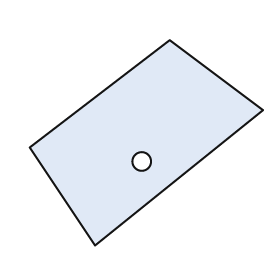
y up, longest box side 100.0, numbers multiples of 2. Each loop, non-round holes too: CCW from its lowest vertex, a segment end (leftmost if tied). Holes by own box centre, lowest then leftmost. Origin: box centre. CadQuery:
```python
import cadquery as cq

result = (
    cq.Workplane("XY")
    .moveTo(-22.0, -44.0)
    .lineTo(50.0, 14.0)
    .lineTo(10.0, 44.0)
    .lineTo(-50.0, -2.0)
    .close()
    .moveTo(-2.0, -8.0)
    .circle(4.0)
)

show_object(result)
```